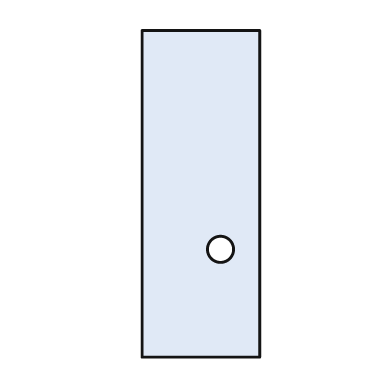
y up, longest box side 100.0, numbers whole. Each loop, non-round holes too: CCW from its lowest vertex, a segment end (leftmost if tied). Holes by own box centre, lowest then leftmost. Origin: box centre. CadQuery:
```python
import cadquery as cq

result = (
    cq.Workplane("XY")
    .moveTo(-18.0, -50.0)
    .lineTo(18.0, -50.0)
    .lineTo(18.0, 50.0)
    .lineTo(-18.0, 50.0)
    .close()
    .moveTo(6.0, -17.0)
    .circle(4.0)
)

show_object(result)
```